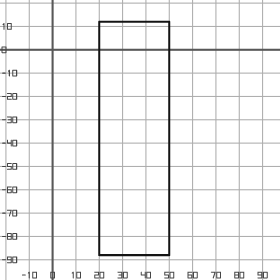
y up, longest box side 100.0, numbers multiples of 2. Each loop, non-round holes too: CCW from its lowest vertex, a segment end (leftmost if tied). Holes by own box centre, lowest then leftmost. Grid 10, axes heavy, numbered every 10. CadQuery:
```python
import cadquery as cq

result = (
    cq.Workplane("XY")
    .moveTo(20.0, -88.0)
    .lineTo(50.0, -88.0)
    .lineTo(50.0, 12.0)
    .lineTo(20.0, 12.0)
    .close()
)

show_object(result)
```